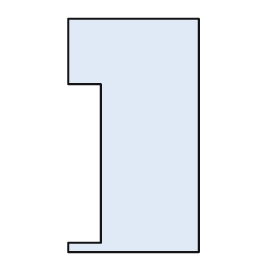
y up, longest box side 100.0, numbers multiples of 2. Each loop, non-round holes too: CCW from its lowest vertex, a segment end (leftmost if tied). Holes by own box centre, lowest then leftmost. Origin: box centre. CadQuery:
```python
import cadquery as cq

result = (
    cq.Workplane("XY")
    .moveTo(-28.0, -50.0)
    .lineTo(28.0, -50.0)
    .lineTo(28.0, 50.0)
    .lineTo(-28.0, 50.0)
    .lineTo(-28.0, 22.0)
    .lineTo(-14.0, 22.0)
    .lineTo(-14.0, -46.0)
    .lineTo(-28.0, -46.0)
    .close()
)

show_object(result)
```